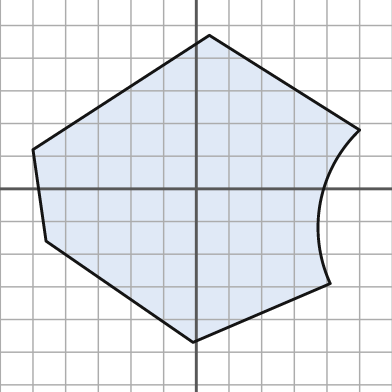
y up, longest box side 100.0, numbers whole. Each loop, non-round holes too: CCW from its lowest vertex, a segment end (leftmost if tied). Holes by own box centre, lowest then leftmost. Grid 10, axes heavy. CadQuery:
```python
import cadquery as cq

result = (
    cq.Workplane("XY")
    .moveTo(-1.0, -47.0)
    .lineTo(41.0, -29.0)
    .threePointArc((38.0, -4.0), (50.0, 18.0))
    .lineTo(4.0, 47.0)
    .lineTo(-50.0, 12.0)
    .lineTo(-46.0, -16.0)
    .close()
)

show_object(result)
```